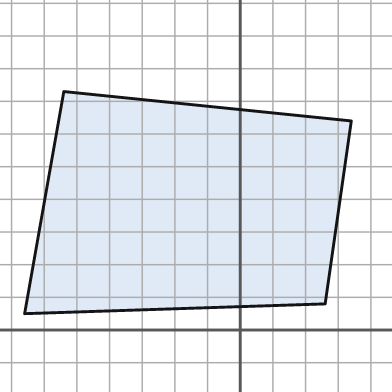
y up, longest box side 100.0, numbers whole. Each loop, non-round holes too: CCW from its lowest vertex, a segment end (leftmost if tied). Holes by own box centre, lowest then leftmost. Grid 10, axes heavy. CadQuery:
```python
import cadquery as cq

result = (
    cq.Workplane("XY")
    .moveTo(-66.0, 5.0)
    .lineTo(26.0, 8.0)
    .lineTo(34.0, 64.0)
    .lineTo(-54.0, 73.0)
    .close()
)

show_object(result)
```